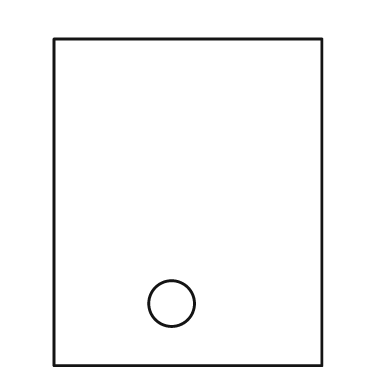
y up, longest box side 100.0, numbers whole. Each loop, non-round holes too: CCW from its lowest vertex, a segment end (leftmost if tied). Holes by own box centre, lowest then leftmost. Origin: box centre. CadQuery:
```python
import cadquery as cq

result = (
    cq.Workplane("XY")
    .moveTo(-41.0, -50.0)
    .lineTo(41.0, -50.0)
    .lineTo(41.0, 50.0)
    .lineTo(-41.0, 50.0)
    .close()
    .moveTo(-5.0, -31.0)
    .circle(7.0)
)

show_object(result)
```